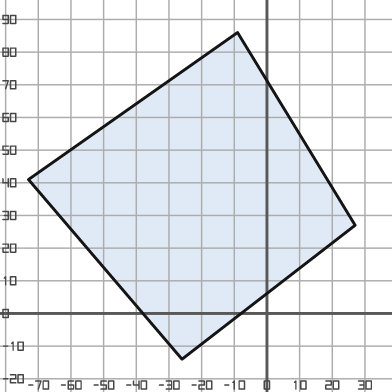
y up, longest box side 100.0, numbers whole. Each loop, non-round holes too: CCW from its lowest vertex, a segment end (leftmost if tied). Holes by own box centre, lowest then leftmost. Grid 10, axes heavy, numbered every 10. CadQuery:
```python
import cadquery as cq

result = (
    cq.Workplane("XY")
    .moveTo(-26.0, -14.0)
    .lineTo(27.0, 27.0)
    .lineTo(-9.0, 86.0)
    .lineTo(-73.0, 41.0)
    .close()
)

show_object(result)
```